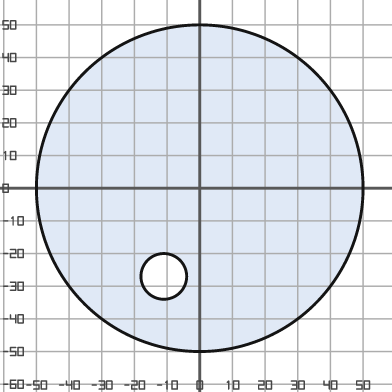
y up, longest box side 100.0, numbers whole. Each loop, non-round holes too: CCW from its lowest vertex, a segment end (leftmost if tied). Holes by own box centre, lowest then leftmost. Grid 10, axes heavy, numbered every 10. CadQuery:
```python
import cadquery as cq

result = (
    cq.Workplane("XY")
    .moveTo(0.0, 0.0)
    .circle(50.0)
    .moveTo(-11.0, -27.0)
    .circle(7.0)
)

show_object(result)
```